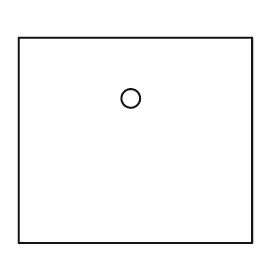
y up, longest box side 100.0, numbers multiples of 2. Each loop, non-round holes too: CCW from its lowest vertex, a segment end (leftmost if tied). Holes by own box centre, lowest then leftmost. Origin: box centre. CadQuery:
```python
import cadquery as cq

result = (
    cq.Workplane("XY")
    .moveTo(-50.0, -44.0)
    .lineTo(50.0, -44.0)
    .lineTo(50.0, 44.0)
    .lineTo(-50.0, 44.0)
    .close()
    .moveTo(-2.0, 18.0)
    .circle(4.0)
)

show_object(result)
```